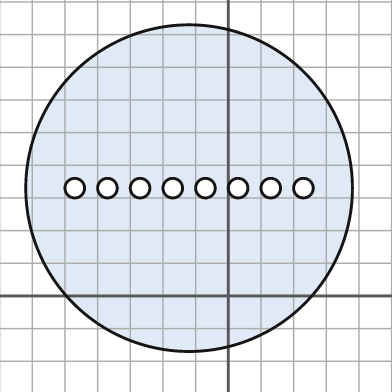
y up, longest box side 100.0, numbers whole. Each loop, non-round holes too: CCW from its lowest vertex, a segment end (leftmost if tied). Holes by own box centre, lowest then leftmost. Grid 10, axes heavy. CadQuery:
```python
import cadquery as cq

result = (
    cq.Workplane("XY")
    .moveTo(-12.0, 33.0)
    .circle(50.0)
    .moveTo(-47.0, 33.0)
    .circle(3.0)
    .moveTo(-37.0, 33.0)
    .circle(3.0)
    .moveTo(-27.0, 33.0)
    .circle(3.0)
    .moveTo(-17.0, 33.0)
    .circle(3.0)
    .moveTo(-7.0, 33.0)
    .circle(3.0)
    .moveTo(3.0, 33.0)
    .circle(3.0)
    .moveTo(13.0, 33.0)
    .circle(3.0)
    .moveTo(23.0, 33.0)
    .circle(3.0)
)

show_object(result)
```